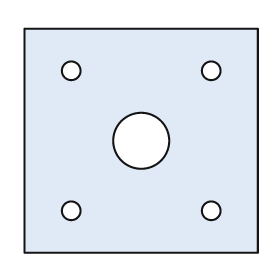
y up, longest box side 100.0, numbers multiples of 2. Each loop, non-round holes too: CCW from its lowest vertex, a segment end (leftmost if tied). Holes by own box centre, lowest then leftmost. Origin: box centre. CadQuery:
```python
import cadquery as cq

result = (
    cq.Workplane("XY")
    .moveTo(-50.0, -48.0)
    .lineTo(50.0, -48.0)
    .lineTo(50.0, 48.0)
    .lineTo(-50.0, 48.0)
    .close()
    .moveTo(-30.0, -30.0)
    .circle(4.0)
    .moveTo(30.0, -30.0)
    .circle(4.0)
    .moveTo(0.0, 0.0)
    .circle(12.0)
    .moveTo(-30.0, 30.0)
    .circle(4.0)
    .moveTo(30.0, 30.0)
    .circle(4.0)
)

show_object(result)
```